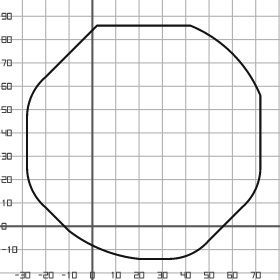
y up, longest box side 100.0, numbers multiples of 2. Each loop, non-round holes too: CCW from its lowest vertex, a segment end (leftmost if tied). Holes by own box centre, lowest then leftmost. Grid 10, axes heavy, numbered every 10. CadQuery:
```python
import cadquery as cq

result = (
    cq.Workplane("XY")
    .moveTo(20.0, -14.0)
    .lineTo(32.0, -14.0)
    .threePointArc((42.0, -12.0), (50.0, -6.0))
    .lineTo(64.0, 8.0)
    .threePointArc((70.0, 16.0), (72.0, 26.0))
    .lineTo(72.0, 56.0)
    .threePointArc((60.0, 74.0), (42.0, 86.0))
    .lineTo(2.0, 86.0)
    .lineTo(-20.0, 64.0)
    .threePointArc((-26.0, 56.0), (-28.0, 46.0))
    .lineTo(-28.0, 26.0)
    .threePointArc((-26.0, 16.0), (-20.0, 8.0))
    .lineTo(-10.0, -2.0)
    .threePointArc((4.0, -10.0), (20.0, -14.0))
    .close()
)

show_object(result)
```